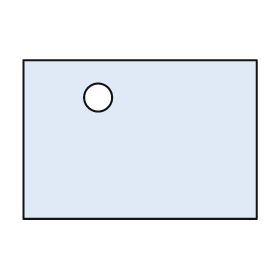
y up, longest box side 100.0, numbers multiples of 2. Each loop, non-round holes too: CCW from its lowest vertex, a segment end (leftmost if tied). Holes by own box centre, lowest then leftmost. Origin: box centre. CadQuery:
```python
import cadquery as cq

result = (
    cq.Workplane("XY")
    .moveTo(-50.0, -34.0)
    .lineTo(50.0, -34.0)
    .lineTo(50.0, 34.0)
    .lineTo(-50.0, 34.0)
    .close()
    .moveTo(-18.0, 18.0)
    .circle(6.0)
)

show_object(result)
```